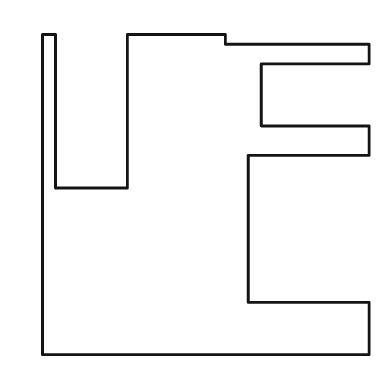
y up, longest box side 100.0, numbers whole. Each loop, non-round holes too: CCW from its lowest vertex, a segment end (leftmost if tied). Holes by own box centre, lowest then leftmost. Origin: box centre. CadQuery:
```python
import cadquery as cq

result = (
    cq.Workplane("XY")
    .moveTo(-50.0, -49.0)
    .lineTo(50.0, -49.0)
    .lineTo(50.0, -33.0)
    .lineTo(13.0, -33.0)
    .lineTo(13.0, 12.0)
    .lineTo(50.0, 12.0)
    .lineTo(50.0, 21.0)
    .lineTo(17.0, 21.0)
    .lineTo(17.0, 40.0)
    .lineTo(50.0, 40.0)
    .lineTo(50.0, 46.0)
    .lineTo(6.0, 46.0)
    .lineTo(6.0, 49.0)
    .lineTo(-24.0, 49.0)
    .lineTo(-24.0, 2.0)
    .lineTo(-46.0, 2.0)
    .lineTo(-46.0, 49.0)
    .lineTo(-50.0, 49.0)
    .close()
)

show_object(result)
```